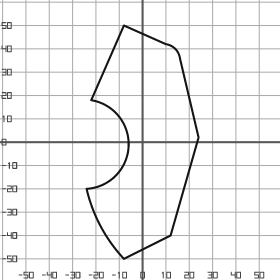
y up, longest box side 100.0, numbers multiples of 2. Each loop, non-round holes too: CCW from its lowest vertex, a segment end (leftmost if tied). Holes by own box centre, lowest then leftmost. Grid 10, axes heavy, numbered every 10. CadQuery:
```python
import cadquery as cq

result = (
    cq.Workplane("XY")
    .moveTo(-8.0, -50.0)
    .lineTo(12.0, -40.0)
    .lineTo(24.0, 2.0)
    .lineTo(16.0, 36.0)
    .threePointArc((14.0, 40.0), (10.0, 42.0))
    .lineTo(-8.0, 50.0)
    .lineTo(-22.0, 18.0)
    .threePointArc((-6.0, -2.0), (-24.0, -20.0))
    .threePointArc((-18.0, -36.0), (-8.0, -50.0))
    .close()
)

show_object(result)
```